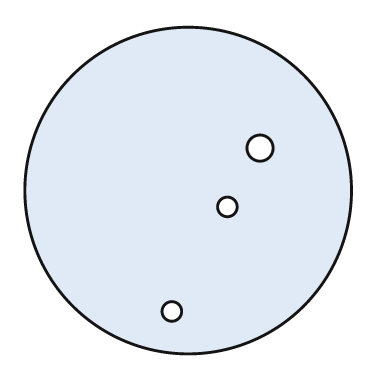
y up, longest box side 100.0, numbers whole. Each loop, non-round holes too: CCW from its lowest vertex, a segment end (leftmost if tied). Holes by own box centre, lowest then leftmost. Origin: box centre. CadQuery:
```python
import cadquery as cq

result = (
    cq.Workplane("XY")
    .moveTo(0.0, 0.0)
    .circle(50.0)
    .moveTo(-5.0, -37.0)
    .circle(3.0)
    .moveTo(12.0, -5.0)
    .circle(3.0)
    .moveTo(22.0, 13.0)
    .circle(4.0)
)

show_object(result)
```